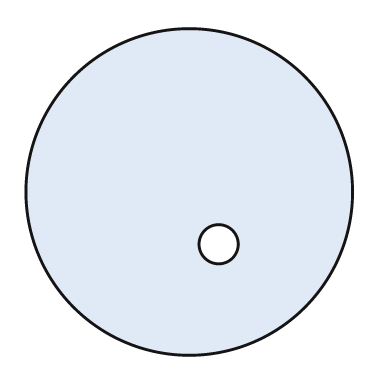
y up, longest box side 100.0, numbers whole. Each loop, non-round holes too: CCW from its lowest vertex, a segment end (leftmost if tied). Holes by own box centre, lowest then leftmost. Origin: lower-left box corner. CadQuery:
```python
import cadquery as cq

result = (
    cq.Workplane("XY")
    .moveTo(50.0, 50.0)
    .circle(50.0)
    .moveTo(59.0, 34.0)
    .circle(6.0)
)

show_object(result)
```